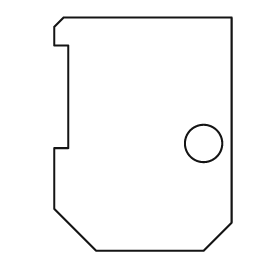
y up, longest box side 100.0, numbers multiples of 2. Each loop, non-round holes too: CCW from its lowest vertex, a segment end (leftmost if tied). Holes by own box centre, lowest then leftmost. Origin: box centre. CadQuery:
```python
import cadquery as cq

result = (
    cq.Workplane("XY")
    .moveTo(-20.0, -50.0)
    .lineTo(26.0, -50.0)
    .lineTo(38.0, -38.0)
    .lineTo(38.0, 50.0)
    .lineTo(-34.0, 50.0)
    .lineTo(-38.0, 46.0)
    .lineTo(-38.0, 38.0)
    .lineTo(-32.0, 38.0)
    .lineTo(-32.0, -6.0)
    .lineTo(-38.0, -6.0)
    .lineTo(-38.0, -32.0)
    .close()
    .moveTo(26.0, -4.0)
    .circle(8.0)
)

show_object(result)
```